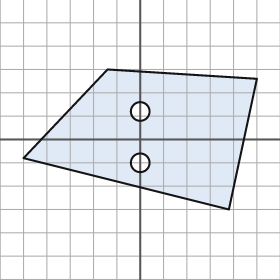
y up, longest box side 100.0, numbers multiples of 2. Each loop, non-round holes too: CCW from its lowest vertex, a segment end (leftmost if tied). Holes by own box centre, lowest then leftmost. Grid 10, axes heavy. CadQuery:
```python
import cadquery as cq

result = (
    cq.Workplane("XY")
    .moveTo(38.0, -30.0)
    .lineTo(50.0, 26.0)
    .lineTo(-14.0, 30.0)
    .lineTo(-50.0, -8.0)
    .close()
    .moveTo(0.0, -10.0)
    .circle(4.0)
    .moveTo(0.0, 12.0)
    .circle(4.0)
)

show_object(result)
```